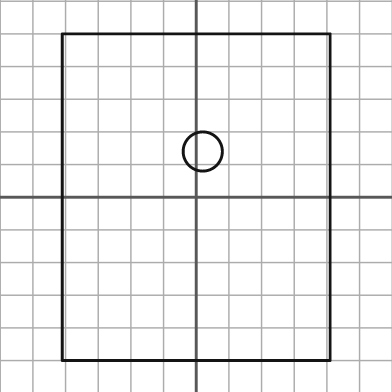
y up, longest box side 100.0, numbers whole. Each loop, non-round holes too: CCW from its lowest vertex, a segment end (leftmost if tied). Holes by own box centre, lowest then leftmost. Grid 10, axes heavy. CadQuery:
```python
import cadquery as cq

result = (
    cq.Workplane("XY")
    .moveTo(-41.0, -50.0)
    .lineTo(41.0, -50.0)
    .lineTo(41.0, 50.0)
    .lineTo(-41.0, 50.0)
    .close()
    .moveTo(2.0, 14.0)
    .circle(6.0)
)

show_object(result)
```